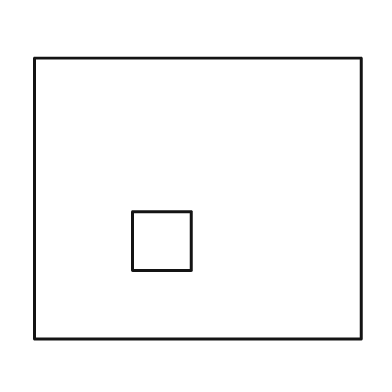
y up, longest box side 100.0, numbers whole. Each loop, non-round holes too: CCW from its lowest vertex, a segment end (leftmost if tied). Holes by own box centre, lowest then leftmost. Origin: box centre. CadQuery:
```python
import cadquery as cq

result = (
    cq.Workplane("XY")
    .moveTo(-50.0, -43.0)
    .lineTo(50.0, -43.0)
    .lineTo(50.0, 43.0)
    .lineTo(-50.0, 43.0)
    .close()
    .moveTo(-20.0, -22.0)
    .lineTo(-2.0, -22.0)
    .lineTo(-2.0, -4.0)
    .lineTo(-20.0, -4.0)
    .close()
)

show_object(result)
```